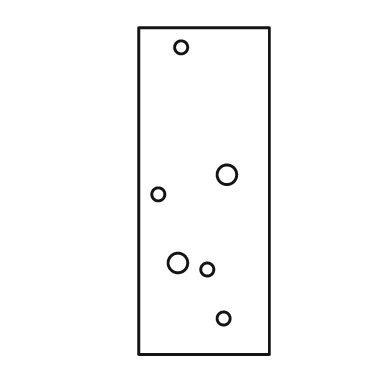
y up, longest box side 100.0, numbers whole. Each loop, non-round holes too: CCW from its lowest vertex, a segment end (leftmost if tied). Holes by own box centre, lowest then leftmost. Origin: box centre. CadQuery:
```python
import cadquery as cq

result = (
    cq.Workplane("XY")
    .moveTo(-20.0, -50.0)
    .lineTo(20.0, -50.0)
    .lineTo(20.0, 50.0)
    .lineTo(-20.0, 50.0)
    .close()
    .moveTo(6.0, -39.0)
    .circle(2.0)
    .moveTo(1.0, -24.0)
    .circle(2.0)
    .moveTo(-8.0, -22.0)
    .circle(3.0)
    .moveTo(-14.0, -1.0)
    .circle(2.0)
    .moveTo(7.0, 5.0)
    .circle(3.0)
    .moveTo(-7.0, 44.0)
    .circle(2.0)
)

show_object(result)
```